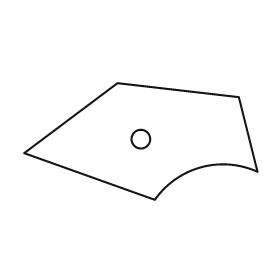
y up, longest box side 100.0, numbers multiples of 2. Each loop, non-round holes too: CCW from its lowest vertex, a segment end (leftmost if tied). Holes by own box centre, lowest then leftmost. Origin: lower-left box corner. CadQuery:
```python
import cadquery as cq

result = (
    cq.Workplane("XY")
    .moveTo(56.0, 0.0)
    .threePointArc((76.0, 14.0), (100.0, 12.0))
    .lineTo(92.0, 44.0)
    .lineTo(40.0, 50.0)
    .lineTo(0.0, 20.0)
    .close()
    .moveTo(50.0, 26.0)
    .circle(4.0)
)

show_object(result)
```